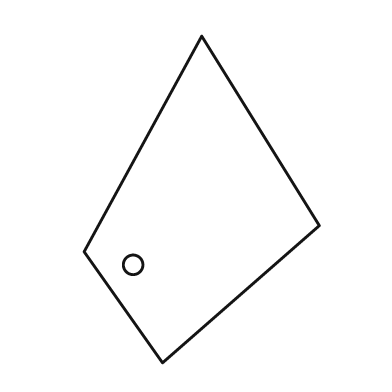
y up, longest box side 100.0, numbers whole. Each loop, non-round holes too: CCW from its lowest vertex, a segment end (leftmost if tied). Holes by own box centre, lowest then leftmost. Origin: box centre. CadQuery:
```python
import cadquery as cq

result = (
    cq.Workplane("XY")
    .moveTo(-12.0, -50.0)
    .lineTo(36.0, -8.0)
    .lineTo(0.0, 50.0)
    .lineTo(-36.0, -16.0)
    .close()
    .moveTo(-21.0, -20.0)
    .circle(3.0)
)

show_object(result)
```